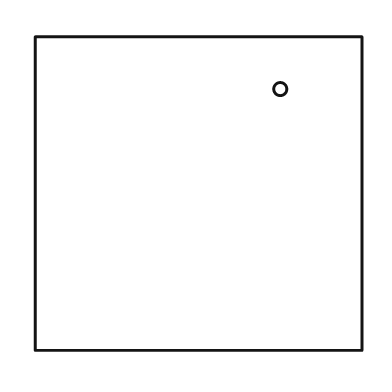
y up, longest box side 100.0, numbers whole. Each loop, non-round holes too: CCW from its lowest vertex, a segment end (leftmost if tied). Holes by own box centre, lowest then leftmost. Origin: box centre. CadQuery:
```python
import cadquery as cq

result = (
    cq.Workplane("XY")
    .moveTo(-50.0, -48.0)
    .lineTo(50.0, -48.0)
    .lineTo(50.0, 48.0)
    .lineTo(-50.0, 48.0)
    .close()
    .moveTo(25.0, 32.0)
    .circle(2.0)
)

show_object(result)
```